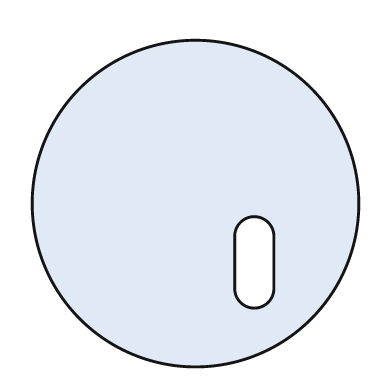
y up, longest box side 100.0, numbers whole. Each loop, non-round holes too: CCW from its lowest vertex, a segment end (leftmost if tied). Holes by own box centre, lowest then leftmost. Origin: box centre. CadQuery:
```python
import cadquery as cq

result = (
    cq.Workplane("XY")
    .moveTo(0.0, 0.0)
    .circle(50.0)
    .moveTo(12.0, -26.0)
    .threePointArc((18.0, -32.0), (24.0, -26.0))
    .lineTo(24.0, -10.0)
    .threePointArc((18.0, -4.0), (12.0, -10.0))
    .close()
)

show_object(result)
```